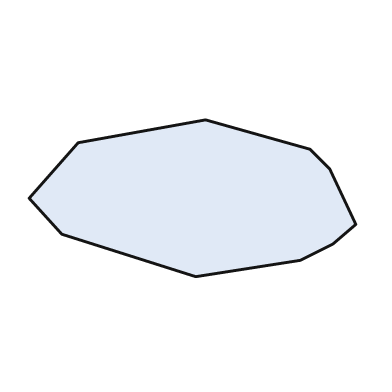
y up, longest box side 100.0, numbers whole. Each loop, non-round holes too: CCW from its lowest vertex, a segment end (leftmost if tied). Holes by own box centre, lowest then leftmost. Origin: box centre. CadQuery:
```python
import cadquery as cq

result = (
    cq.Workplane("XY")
    .moveTo(1.0, -24.0)
    .lineTo(33.0, -19.0)
    .lineTo(43.0, -14.0)
    .lineTo(50.0, -8.0)
    .lineTo(42.0, 9.0)
    .lineTo(36.0, 15.0)
    .lineTo(4.0, 24.0)
    .lineTo(-35.0, 17.0)
    .lineTo(-50.0, 0.0)
    .lineTo(-40.0, -11.0)
    .close()
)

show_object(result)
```